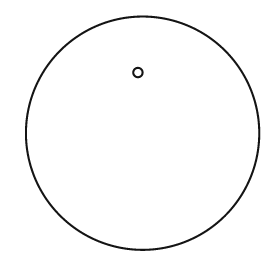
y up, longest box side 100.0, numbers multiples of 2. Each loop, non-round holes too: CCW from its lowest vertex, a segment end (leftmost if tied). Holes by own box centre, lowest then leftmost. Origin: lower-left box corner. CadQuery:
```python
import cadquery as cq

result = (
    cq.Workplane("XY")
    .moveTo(50.0, 50.0)
    .circle(50.0)
    .moveTo(48.0, 76.0)
    .circle(2.0)
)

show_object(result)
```